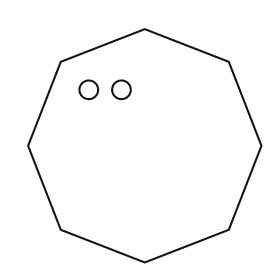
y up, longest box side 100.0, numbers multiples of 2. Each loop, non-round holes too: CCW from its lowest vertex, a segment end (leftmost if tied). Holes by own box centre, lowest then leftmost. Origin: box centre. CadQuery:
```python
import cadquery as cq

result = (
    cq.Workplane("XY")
    .moveTo(0.0, -50.0)
    .lineTo(36.0, -36.0)
    .lineTo(50.0, 0.0)
    .lineTo(36.0, 36.0)
    .lineTo(0.0, 50.0)
    .lineTo(-36.0, 36.0)
    .lineTo(-50.0, 0.0)
    .lineTo(-36.0, -36.0)
    .close()
    .moveTo(-24.0, 24.0)
    .circle(4.0)
    .moveTo(-10.0, 24.0)
    .circle(4.0)
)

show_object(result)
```